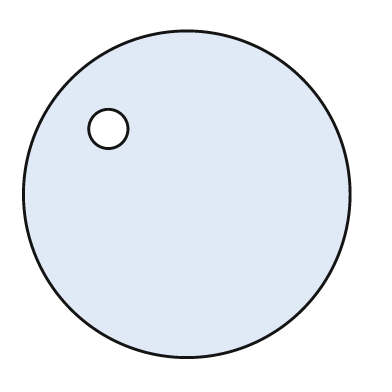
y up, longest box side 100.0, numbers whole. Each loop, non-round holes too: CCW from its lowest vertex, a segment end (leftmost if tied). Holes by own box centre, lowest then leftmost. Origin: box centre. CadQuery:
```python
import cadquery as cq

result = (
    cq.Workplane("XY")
    .moveTo(0.0, 0.0)
    .circle(50.0)
    .moveTo(-24.0, 20.0)
    .circle(6.0)
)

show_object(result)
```